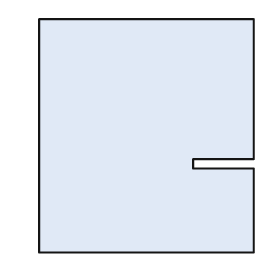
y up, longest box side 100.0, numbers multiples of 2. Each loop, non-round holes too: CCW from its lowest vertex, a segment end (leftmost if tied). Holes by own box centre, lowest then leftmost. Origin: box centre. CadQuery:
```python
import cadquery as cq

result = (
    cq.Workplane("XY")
    .moveTo(-46.0, -50.0)
    .lineTo(46.0, -50.0)
    .lineTo(46.0, -14.0)
    .lineTo(20.0, -14.0)
    .lineTo(20.0, -10.0)
    .lineTo(46.0, -10.0)
    .lineTo(46.0, 50.0)
    .lineTo(-46.0, 50.0)
    .close()
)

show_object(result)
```